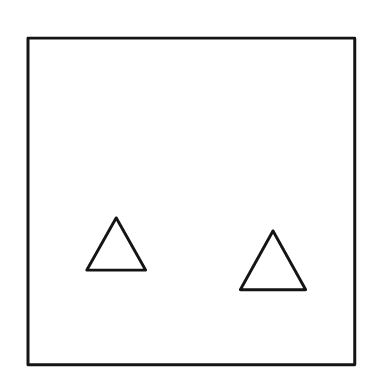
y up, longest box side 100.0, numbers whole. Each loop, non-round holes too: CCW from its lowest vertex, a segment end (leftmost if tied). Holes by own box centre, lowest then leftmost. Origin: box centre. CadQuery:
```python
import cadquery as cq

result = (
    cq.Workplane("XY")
    .moveTo(-50.0, -50.0)
    .lineTo(50.0, -50.0)
    .lineTo(50.0, 50.0)
    .lineTo(-50.0, 50.0)
    .close()
    .moveTo(15.0, -27.0)
    .lineTo(35.0, -27.0)
    .lineTo(25.0, -9.0)
    .close()
    .moveTo(-32.0, -21.0)
    .lineTo(-14.0, -21.0)
    .lineTo(-23.0, -5.0)
    .close()
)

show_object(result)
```